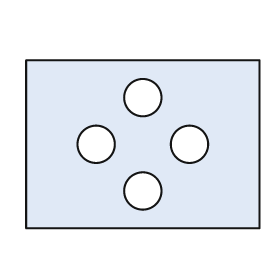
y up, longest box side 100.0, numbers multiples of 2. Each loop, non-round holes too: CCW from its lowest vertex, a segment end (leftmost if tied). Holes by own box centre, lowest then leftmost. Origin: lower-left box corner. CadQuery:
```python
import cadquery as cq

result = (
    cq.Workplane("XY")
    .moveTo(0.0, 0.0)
    .lineTo(100.0, 0.0)
    .lineTo(100.0, 72.0)
    .lineTo(0.0, 72.0)
    .close()
    .moveTo(50.0, 16.0)
    .circle(8.0)
    .moveTo(30.0, 36.0)
    .circle(8.0)
    .moveTo(70.0, 36.0)
    .circle(8.0)
    .moveTo(50.0, 56.0)
    .circle(8.0)
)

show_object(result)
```